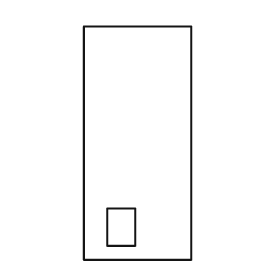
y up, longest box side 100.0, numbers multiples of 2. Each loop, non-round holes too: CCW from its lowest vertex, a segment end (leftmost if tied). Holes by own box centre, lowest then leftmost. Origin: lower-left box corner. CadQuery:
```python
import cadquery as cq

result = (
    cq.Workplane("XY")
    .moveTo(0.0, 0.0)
    .lineTo(46.0, 0.0)
    .lineTo(46.0, 100.0)
    .lineTo(0.0, 100.0)
    .close()
    .moveTo(10.0, 6.0)
    .lineTo(22.0, 6.0)
    .lineTo(22.0, 22.0)
    .lineTo(10.0, 22.0)
    .close()
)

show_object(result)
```